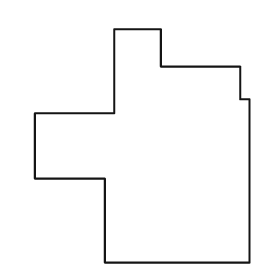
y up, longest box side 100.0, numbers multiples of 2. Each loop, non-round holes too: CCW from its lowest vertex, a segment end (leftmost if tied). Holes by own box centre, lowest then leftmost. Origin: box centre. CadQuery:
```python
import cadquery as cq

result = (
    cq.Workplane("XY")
    .moveTo(-16.0, -50.0)
    .lineTo(46.0, -50.0)
    .lineTo(46.0, 20.0)
    .lineTo(42.0, 20.0)
    .lineTo(42.0, 34.0)
    .lineTo(8.0, 34.0)
    .lineTo(8.0, 50.0)
    .lineTo(-12.0, 50.0)
    .lineTo(-12.0, 14.0)
    .lineTo(-46.0, 14.0)
    .lineTo(-46.0, -14.0)
    .lineTo(-16.0, -14.0)
    .close()
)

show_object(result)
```